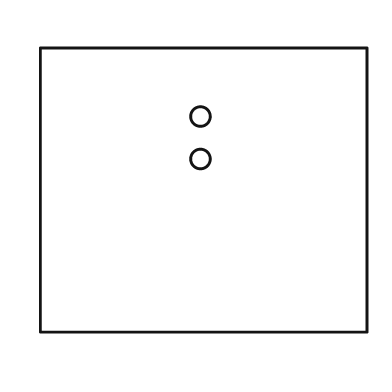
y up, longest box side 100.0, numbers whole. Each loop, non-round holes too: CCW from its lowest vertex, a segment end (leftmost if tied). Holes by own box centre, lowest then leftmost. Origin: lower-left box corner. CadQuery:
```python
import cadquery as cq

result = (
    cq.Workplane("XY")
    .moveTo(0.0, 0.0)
    .lineTo(100.0, 0.0)
    .lineTo(100.0, 87.0)
    .lineTo(0.0, 87.0)
    .close()
    .moveTo(49.0, 53.0)
    .circle(3.0)
    .moveTo(49.0, 66.0)
    .circle(3.0)
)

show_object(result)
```